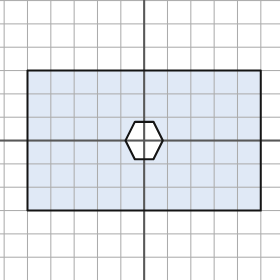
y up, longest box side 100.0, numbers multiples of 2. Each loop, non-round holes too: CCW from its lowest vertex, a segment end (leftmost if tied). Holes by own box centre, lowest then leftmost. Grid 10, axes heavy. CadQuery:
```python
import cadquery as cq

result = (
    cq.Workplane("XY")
    .moveTo(-50.0, -30.0)
    .lineTo(50.0, -30.0)
    .lineTo(50.0, 30.0)
    .lineTo(-50.0, 30.0)
    .close()
    .moveTo(-4.0, -8.0)
    .lineTo(4.0, -8.0)
    .lineTo(8.0, 0.0)
    .lineTo(4.0, 8.0)
    .lineTo(-4.0, 8.0)
    .lineTo(-8.0, 0.0)
    .close()
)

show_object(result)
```